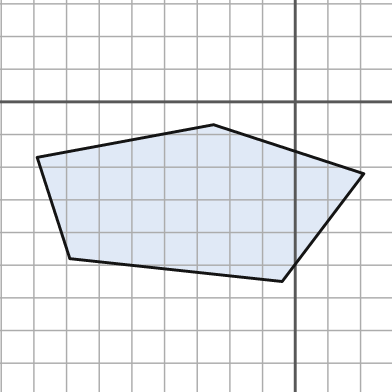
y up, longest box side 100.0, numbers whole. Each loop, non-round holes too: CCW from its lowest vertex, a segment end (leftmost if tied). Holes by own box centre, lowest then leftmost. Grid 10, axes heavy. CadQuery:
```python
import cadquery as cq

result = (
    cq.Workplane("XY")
    .moveTo(-4.0, -55.0)
    .lineTo(21.0, -22.0)
    .lineTo(-25.0, -7.0)
    .lineTo(-79.0, -17.0)
    .lineTo(-69.0, -48.0)
    .close()
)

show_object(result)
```